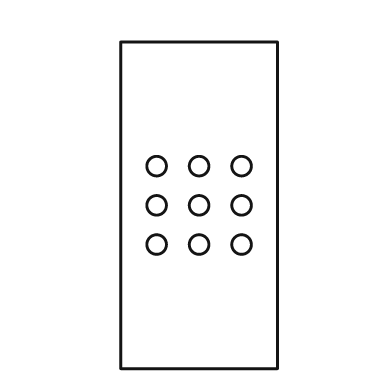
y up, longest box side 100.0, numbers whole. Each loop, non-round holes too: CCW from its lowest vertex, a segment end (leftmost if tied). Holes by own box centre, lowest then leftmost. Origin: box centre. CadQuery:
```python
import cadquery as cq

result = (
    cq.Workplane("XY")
    .moveTo(-24.0, -50.0)
    .lineTo(24.0, -50.0)
    .lineTo(24.0, 50.0)
    .lineTo(-24.0, 50.0)
    .close()
    .moveTo(-13.0, -12.0)
    .circle(3.0)
    .moveTo(0.0, -12.0)
    .circle(3.0)
    .moveTo(13.0, -12.0)
    .circle(3.0)
    .moveTo(-13.0, 0.0)
    .circle(3.0)
    .moveTo(0.0, 0.0)
    .circle(3.0)
    .moveTo(13.0, 0.0)
    .circle(3.0)
    .moveTo(-13.0, 12.0)
    .circle(3.0)
    .moveTo(0.0, 12.0)
    .circle(3.0)
    .moveTo(13.0, 12.0)
    .circle(3.0)
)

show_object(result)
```